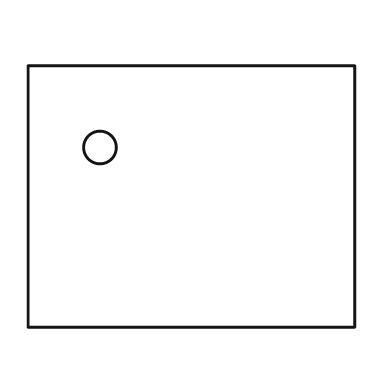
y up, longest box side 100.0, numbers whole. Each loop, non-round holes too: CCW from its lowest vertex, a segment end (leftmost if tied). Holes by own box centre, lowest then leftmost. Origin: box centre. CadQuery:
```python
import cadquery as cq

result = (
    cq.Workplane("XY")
    .moveTo(-50.0, -40.0)
    .lineTo(50.0, -40.0)
    .lineTo(50.0, 40.0)
    .lineTo(-50.0, 40.0)
    .close()
    .moveTo(-28.0, 15.0)
    .circle(5.0)
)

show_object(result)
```